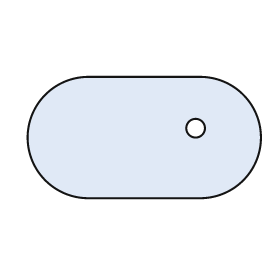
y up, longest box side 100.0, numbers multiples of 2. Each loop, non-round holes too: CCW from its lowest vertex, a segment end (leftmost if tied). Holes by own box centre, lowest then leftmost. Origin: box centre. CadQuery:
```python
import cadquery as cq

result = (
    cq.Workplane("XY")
    .moveTo(-24.0, -26.0)
    .lineTo(24.0, -26.0)
    .threePointArc((50.0, 0.0), (24.0, 26.0))
    .lineTo(-24.0, 26.0)
    .threePointArc((-50.0, 0.0), (-24.0, -26.0))
    .close()
    .moveTo(22.0, 4.0)
    .circle(4.0)
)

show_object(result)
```